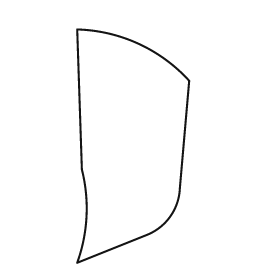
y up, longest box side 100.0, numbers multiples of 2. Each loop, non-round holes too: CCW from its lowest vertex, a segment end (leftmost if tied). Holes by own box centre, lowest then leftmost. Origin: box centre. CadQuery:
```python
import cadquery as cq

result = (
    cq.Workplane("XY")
    .moveTo(-24.0, -50.0)
    .lineTo(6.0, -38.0)
    .threePointArc((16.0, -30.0), (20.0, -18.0))
    .lineTo(24.0, 28.0)
    .threePointArc((2.0, 44.0), (-24.0, 50.0))
    .lineTo(-22.0, -10.0)
    .threePointArc((-20.0, -30.0), (-24.0, -50.0))
    .close()
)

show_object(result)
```